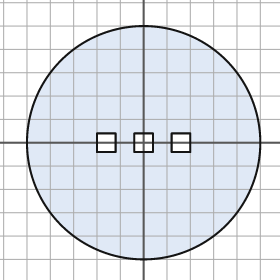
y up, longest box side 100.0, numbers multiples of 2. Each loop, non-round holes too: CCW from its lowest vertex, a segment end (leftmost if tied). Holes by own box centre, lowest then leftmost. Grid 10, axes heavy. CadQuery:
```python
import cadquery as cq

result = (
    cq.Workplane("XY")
    .moveTo(0.0, 0.0)
    .circle(50.0)
    .moveTo(-20.0, -4.0)
    .lineTo(-12.0, -4.0)
    .lineTo(-12.0, 4.0)
    .lineTo(-20.0, 4.0)
    .close()
    .moveTo(-4.0, -4.0)
    .lineTo(4.0, -4.0)
    .lineTo(4.0, 4.0)
    .lineTo(-4.0, 4.0)
    .close()
    .moveTo(12.0, -4.0)
    .lineTo(20.0, -4.0)
    .lineTo(20.0, 4.0)
    .lineTo(12.0, 4.0)
    .close()
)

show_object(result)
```